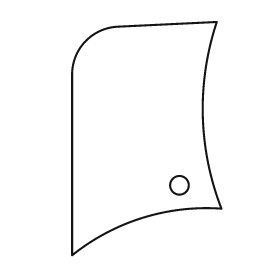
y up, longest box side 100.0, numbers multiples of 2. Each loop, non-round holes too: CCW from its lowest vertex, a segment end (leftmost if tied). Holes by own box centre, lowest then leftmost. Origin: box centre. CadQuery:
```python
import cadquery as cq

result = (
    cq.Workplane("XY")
    .moveTo(-32.0, -50.0)
    .threePointArc((-2.0, -34.0), (32.0, -30.0))
    .threePointArc((24.0, 10.0), (30.0, 50.0))
    .lineTo(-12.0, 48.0)
    .threePointArc((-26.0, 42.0), (-32.0, 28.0))
    .close()
    .moveTo(14.0, -20.0)
    .circle(4.0)
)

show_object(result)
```